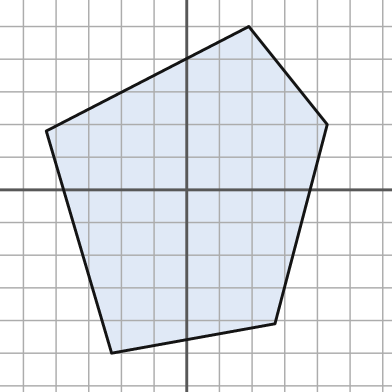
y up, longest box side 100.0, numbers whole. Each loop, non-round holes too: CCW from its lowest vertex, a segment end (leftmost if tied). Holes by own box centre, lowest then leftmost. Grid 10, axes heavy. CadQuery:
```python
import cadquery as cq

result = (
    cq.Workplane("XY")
    .moveTo(-23.0, -50.0)
    .lineTo(27.0, -41.0)
    .lineTo(43.0, 20.0)
    .lineTo(19.0, 50.0)
    .lineTo(-43.0, 18.0)
    .close()
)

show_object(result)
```